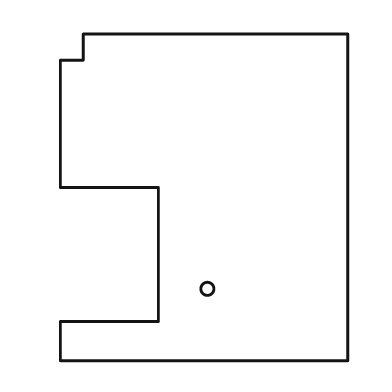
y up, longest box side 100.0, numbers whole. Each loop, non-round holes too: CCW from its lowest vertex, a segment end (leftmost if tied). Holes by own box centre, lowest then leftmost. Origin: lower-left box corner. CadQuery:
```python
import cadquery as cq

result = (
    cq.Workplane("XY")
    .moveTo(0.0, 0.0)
    .lineTo(88.0, 0.0)
    .lineTo(88.0, 100.0)
    .lineTo(7.0, 100.0)
    .lineTo(7.0, 92.0)
    .lineTo(0.0, 92.0)
    .lineTo(0.0, 53.0)
    .lineTo(30.0, 53.0)
    .lineTo(30.0, 12.0)
    .lineTo(0.0, 12.0)
    .close()
    .moveTo(45.0, 22.0)
    .circle(2.0)
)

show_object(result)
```